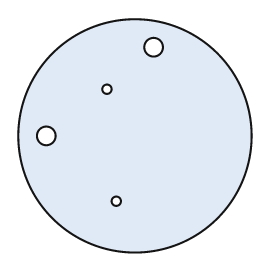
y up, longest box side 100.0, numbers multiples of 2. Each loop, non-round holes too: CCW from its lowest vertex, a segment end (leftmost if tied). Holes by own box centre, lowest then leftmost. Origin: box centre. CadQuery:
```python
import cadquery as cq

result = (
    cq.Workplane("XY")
    .moveTo(0.0, 0.0)
    .circle(50.0)
    .moveTo(-8.0, -28.0)
    .circle(2.0)
    .moveTo(-38.0, 0.0)
    .circle(4.0)
    .moveTo(-12.0, 20.0)
    .circle(2.0)
    .moveTo(8.0, 38.0)
    .circle(4.0)
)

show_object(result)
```